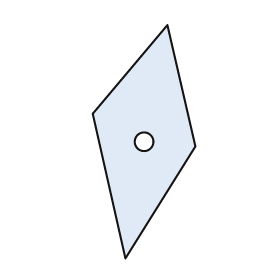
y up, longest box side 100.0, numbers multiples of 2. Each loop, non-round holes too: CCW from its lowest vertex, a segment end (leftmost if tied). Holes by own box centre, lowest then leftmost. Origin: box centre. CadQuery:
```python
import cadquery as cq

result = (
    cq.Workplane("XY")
    .moveTo(-8.0, -50.0)
    .lineTo(22.0, -2.0)
    .lineTo(10.0, 50.0)
    .lineTo(-22.0, 12.0)
    .close()
    .moveTo(0.0, 0.0)
    .circle(4.0)
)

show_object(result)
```